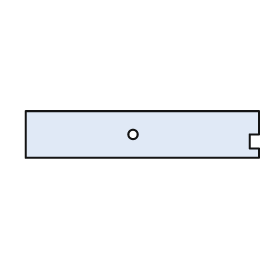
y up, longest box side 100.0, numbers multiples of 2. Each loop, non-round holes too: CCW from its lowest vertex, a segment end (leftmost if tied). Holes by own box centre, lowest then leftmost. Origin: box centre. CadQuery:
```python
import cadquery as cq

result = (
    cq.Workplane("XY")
    .moveTo(-50.0, -10.0)
    .lineTo(50.0, -10.0)
    .lineTo(50.0, -6.0)
    .lineTo(46.0, -6.0)
    .lineTo(46.0, 0.0)
    .lineTo(50.0, 0.0)
    .lineTo(50.0, 10.0)
    .lineTo(-50.0, 10.0)
    .close()
    .moveTo(-4.0, 0.0)
    .circle(2.0)
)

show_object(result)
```